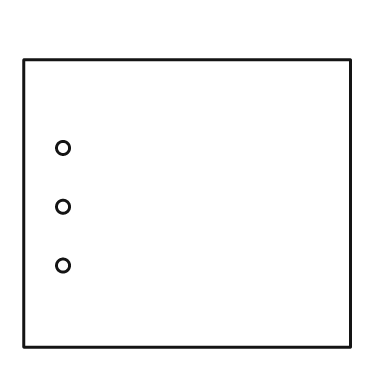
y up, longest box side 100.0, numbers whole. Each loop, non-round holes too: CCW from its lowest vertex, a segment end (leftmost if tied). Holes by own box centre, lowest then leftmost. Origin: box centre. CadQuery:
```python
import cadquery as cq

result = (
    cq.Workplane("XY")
    .moveTo(-50.0, -44.0)
    .lineTo(50.0, -44.0)
    .lineTo(50.0, 44.0)
    .lineTo(-50.0, 44.0)
    .close()
    .moveTo(-38.0, -19.0)
    .circle(2.0)
    .moveTo(-38.0, -1.0)
    .circle(2.0)
    .moveTo(-38.0, 17.0)
    .circle(2.0)
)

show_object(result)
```